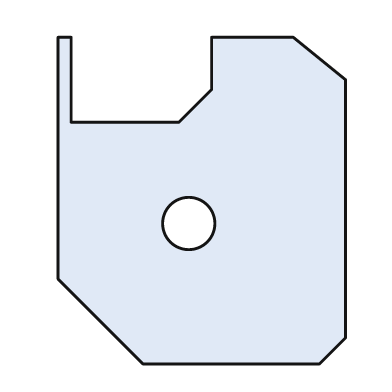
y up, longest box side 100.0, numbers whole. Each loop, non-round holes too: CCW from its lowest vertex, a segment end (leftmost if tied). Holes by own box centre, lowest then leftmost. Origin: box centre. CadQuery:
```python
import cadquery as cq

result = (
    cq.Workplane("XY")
    .moveTo(-18.0, -50.0)
    .lineTo(36.0, -50.0)
    .lineTo(44.0, -42.0)
    .lineTo(44.0, 37.0)
    .lineTo(28.0, 50.0)
    .lineTo(3.0, 50.0)
    .lineTo(3.0, 34.0)
    .lineTo(-7.0, 24.0)
    .lineTo(-40.0, 24.0)
    .lineTo(-40.0, 50.0)
    .lineTo(-44.0, 50.0)
    .lineTo(-44.0, -24.0)
    .close()
    .moveTo(-4.0, -7.0)
    .circle(8.0)
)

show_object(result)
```